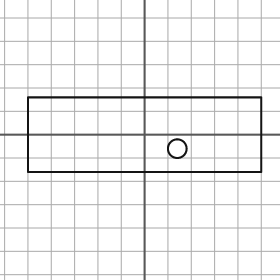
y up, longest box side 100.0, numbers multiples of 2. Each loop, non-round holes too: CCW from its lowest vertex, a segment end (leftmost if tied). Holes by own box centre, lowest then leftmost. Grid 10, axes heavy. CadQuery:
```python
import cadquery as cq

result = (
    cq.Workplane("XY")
    .moveTo(-50.0, -16.0)
    .lineTo(50.0, -16.0)
    .lineTo(50.0, 16.0)
    .lineTo(-50.0, 16.0)
    .close()
    .moveTo(14.0, -6.0)
    .circle(4.0)
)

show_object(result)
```